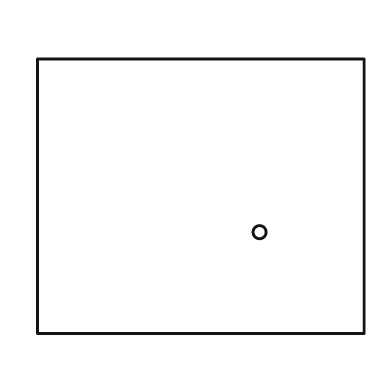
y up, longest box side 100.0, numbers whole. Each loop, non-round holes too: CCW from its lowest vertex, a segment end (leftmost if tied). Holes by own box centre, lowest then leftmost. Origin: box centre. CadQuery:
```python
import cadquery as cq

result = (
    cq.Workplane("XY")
    .moveTo(-50.0, -42.0)
    .lineTo(50.0, -42.0)
    .lineTo(50.0, 42.0)
    .lineTo(-50.0, 42.0)
    .close()
    .moveTo(18.0, -11.0)
    .circle(2.0)
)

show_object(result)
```